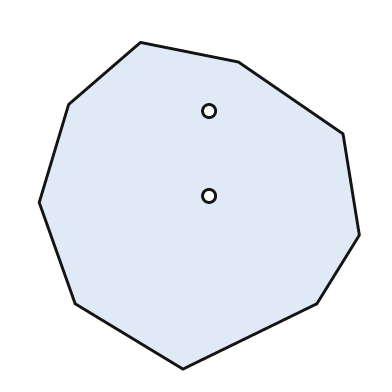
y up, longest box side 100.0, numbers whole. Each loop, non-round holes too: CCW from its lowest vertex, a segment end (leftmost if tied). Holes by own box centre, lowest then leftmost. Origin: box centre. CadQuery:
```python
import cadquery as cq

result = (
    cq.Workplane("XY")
    .moveTo(-5.0, -50.0)
    .lineTo(36.0, -30.0)
    .lineTo(49.0, -9.0)
    .lineTo(44.0, 22.0)
    .lineTo(12.0, 44.0)
    .lineTo(-18.0, 50.0)
    .lineTo(-40.0, 31.0)
    .lineTo(-49.0, 1.0)
    .lineTo(-38.0, -30.0)
    .close()
    .moveTo(3.0, 3.0)
    .circle(2.0)
    .moveTo(3.0, 29.0)
    .circle(2.0)
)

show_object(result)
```